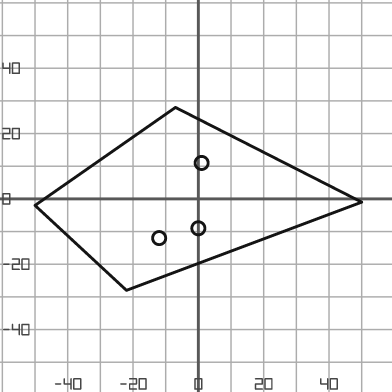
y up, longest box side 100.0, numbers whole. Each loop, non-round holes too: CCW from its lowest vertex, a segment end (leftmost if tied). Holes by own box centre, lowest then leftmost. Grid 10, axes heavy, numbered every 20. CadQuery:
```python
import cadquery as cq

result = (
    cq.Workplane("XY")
    .moveTo(-22.0, -28.0)
    .lineTo(50.0, -1.0)
    .lineTo(-7.0, 28.0)
    .lineTo(-50.0, -2.0)
    .close()
    .moveTo(-12.0, -12.0)
    .circle(2.0)
    .moveTo(0.0, -9.0)
    .circle(2.0)
    .moveTo(1.0, 11.0)
    .circle(2.0)
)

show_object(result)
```